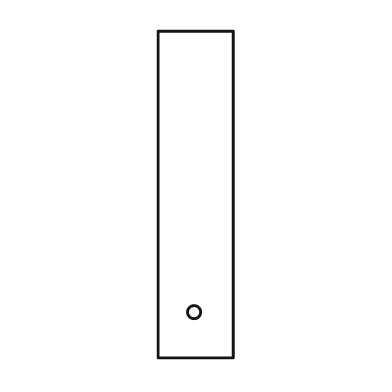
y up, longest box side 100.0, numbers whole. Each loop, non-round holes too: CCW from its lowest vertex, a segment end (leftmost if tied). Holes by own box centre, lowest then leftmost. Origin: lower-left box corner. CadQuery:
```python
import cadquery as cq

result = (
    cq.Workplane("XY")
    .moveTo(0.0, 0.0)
    .lineTo(23.0, 0.0)
    .lineTo(23.0, 100.0)
    .lineTo(0.0, 100.0)
    .close()
    .moveTo(11.0, 14.0)
    .circle(2.0)
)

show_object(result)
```